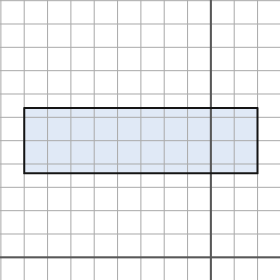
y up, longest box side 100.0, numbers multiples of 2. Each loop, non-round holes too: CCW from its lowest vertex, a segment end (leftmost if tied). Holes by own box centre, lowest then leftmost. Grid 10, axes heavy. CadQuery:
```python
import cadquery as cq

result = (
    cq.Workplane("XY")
    .moveTo(-80.0, 36.0)
    .lineTo(20.0, 36.0)
    .lineTo(20.0, 64.0)
    .lineTo(-80.0, 64.0)
    .close()
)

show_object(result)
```